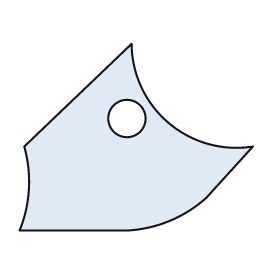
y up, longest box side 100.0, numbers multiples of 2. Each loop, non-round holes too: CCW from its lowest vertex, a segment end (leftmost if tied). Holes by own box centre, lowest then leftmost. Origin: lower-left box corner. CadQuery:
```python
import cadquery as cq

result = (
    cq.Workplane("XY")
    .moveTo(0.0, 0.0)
    .lineTo(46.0, 0.0)
    .threePointArc((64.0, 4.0), (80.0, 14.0))
    .lineTo(100.0, 36.0)
    .threePointArc((64.0, 46.0), (48.0, 80.0))
    .lineTo(2.0, 36.0)
    .threePointArc((4.0, 18.0), (0.0, 0.0))
    .close()
    .moveTo(46.0, 48.0)
    .circle(8.0)
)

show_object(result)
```